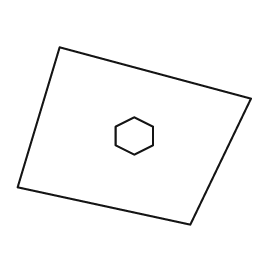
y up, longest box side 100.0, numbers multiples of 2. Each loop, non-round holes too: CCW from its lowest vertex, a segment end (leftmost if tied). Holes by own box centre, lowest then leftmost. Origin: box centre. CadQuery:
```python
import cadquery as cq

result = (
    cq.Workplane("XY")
    .moveTo(24.0, -38.0)
    .lineTo(50.0, 16.0)
    .lineTo(-32.0, 38.0)
    .lineTo(-50.0, -22.0)
    .close()
    .moveTo(0.0, -8.0)
    .lineTo(8.0, -4.0)
    .lineTo(8.0, 4.0)
    .lineTo(0.0, 8.0)
    .lineTo(-8.0, 4.0)
    .lineTo(-8.0, -4.0)
    .close()
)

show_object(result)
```